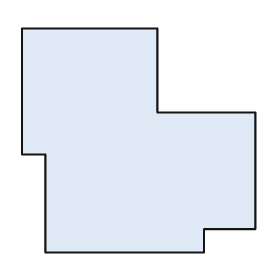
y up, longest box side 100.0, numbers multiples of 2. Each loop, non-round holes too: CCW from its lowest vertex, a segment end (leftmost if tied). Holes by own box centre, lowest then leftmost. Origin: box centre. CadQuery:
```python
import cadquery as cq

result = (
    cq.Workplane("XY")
    .moveTo(-40.0, -48.0)
    .lineTo(28.0, -48.0)
    .lineTo(28.0, -38.0)
    .lineTo(50.0, -38.0)
    .lineTo(50.0, 12.0)
    .lineTo(8.0, 12.0)
    .lineTo(8.0, 48.0)
    .lineTo(-50.0, 48.0)
    .lineTo(-50.0, -6.0)
    .lineTo(-40.0, -6.0)
    .close()
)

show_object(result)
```